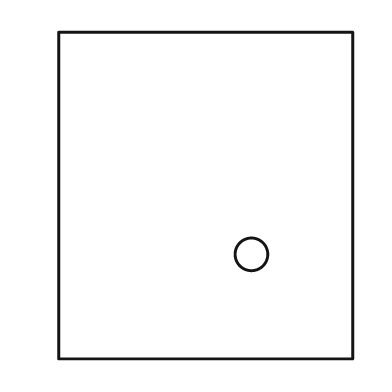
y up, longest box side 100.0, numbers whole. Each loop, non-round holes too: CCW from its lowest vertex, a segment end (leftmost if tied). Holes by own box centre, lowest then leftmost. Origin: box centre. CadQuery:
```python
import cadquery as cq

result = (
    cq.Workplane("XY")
    .moveTo(-45.0, -50.0)
    .lineTo(45.0, -50.0)
    .lineTo(45.0, 50.0)
    .lineTo(-45.0, 50.0)
    .close()
    .moveTo(14.0, -18.0)
    .circle(5.0)
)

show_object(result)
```